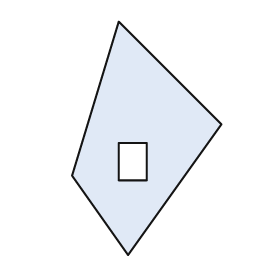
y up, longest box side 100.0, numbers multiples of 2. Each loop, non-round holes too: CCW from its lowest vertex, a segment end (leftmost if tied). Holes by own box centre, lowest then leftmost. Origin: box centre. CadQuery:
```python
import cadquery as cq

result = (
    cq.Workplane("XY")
    .moveTo(-8.0, -50.0)
    .lineTo(32.0, 6.0)
    .lineTo(-12.0, 50.0)
    .lineTo(-32.0, -16.0)
    .close()
    .moveTo(-12.0, -18.0)
    .lineTo(0.0, -18.0)
    .lineTo(0.0, -2.0)
    .lineTo(-12.0, -2.0)
    .close()
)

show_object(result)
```